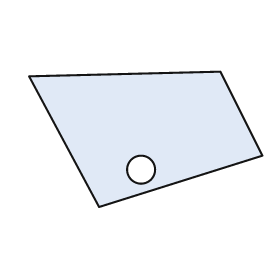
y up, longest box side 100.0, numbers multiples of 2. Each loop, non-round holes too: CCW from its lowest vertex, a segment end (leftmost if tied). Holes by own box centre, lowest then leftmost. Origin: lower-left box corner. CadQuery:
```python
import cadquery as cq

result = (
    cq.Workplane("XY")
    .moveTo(30.0, 0.0)
    .lineTo(100.0, 22.0)
    .lineTo(82.0, 58.0)
    .lineTo(0.0, 56.0)
    .close()
    .moveTo(48.0, 16.0)
    .circle(6.0)
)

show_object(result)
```